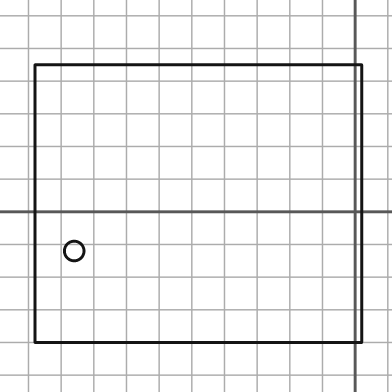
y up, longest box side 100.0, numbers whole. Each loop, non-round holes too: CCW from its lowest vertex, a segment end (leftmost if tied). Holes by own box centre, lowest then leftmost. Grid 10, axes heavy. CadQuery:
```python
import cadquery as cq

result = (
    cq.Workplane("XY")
    .moveTo(-98.0, -40.0)
    .lineTo(2.0, -40.0)
    .lineTo(2.0, 45.0)
    .lineTo(-98.0, 45.0)
    .close()
    .moveTo(-86.0, -12.0)
    .circle(3.0)
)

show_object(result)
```